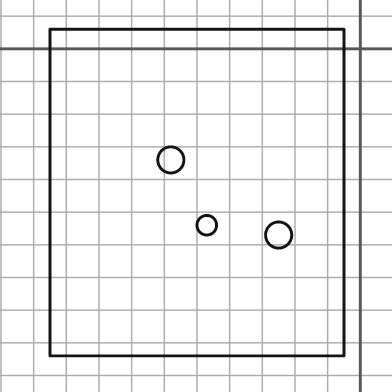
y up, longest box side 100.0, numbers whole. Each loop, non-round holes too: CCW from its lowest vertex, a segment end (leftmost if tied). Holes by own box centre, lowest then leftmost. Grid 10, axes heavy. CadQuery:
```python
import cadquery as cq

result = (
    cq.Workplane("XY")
    .moveTo(-95.0, -94.0)
    .lineTo(-5.0, -94.0)
    .lineTo(-5.0, 6.0)
    .lineTo(-95.0, 6.0)
    .close()
    .moveTo(-25.0, -57.0)
    .circle(4.0)
    .moveTo(-47.0, -54.0)
    .circle(3.0)
    .moveTo(-58.0, -34.0)
    .circle(4.0)
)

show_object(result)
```